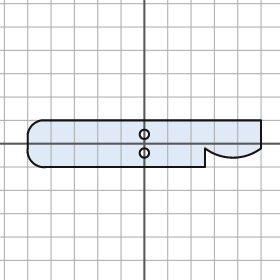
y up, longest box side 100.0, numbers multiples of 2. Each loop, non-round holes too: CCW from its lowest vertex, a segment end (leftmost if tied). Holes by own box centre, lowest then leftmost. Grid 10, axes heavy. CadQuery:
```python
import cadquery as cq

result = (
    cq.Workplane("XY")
    .moveTo(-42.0, -10.0)
    .lineTo(26.0, -10.0)
    .lineTo(26.0, -2.0)
    .threePointArc((38.0, -6.0), (50.0, -2.0))
    .lineTo(50.0, 10.0)
    .lineTo(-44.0, 10.0)
    .threePointArc((-48.0, 8.0), (-50.0, 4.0))
    .lineTo(-50.0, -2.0)
    .threePointArc((-48.0, -8.0), (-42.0, -10.0))
    .close()
    .moveTo(0.0, -4.0)
    .circle(2.0)
    .moveTo(0.0, 4.0)
    .circle(2.0)
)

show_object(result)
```